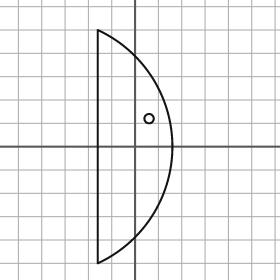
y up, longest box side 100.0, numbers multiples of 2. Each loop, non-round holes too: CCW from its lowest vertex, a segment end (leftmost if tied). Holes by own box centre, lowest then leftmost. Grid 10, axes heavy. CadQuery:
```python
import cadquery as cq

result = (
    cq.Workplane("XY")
    .moveTo(-16.0, -50.0)
    .threePointArc((16.0, 0.0), (-16.0, 50.0))
    .close()
    .moveTo(6.0, 12.0)
    .circle(2.0)
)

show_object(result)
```